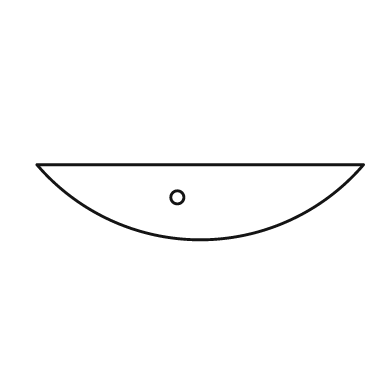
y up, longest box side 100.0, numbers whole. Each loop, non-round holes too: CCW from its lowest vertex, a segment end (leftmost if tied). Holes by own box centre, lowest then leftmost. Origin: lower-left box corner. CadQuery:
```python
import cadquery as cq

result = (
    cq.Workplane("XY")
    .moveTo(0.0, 23.0)
    .threePointArc((50.0, 0.0), (100.0, 23.0))
    .close()
    .moveTo(43.0, 13.0)
    .circle(2.0)
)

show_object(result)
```